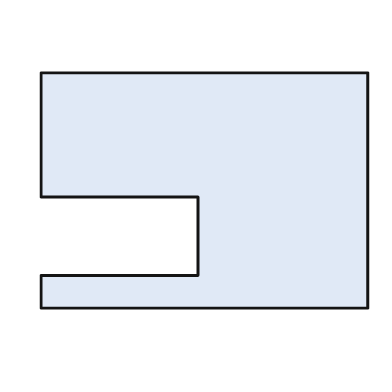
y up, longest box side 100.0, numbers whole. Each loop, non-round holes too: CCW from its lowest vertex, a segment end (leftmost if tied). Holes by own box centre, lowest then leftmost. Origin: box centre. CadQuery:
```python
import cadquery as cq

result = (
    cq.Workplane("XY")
    .moveTo(-50.0, -36.0)
    .lineTo(50.0, -36.0)
    .lineTo(50.0, 36.0)
    .lineTo(-50.0, 36.0)
    .lineTo(-50.0, -2.0)
    .lineTo(-2.0, -2.0)
    .lineTo(-2.0, -26.0)
    .lineTo(-50.0, -26.0)
    .close()
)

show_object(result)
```